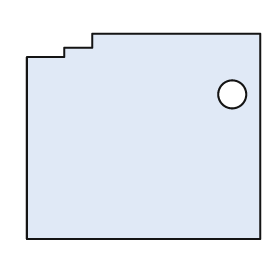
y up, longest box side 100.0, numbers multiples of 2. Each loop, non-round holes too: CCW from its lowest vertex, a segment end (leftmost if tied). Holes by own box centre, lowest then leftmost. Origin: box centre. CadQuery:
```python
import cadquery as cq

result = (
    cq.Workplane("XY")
    .moveTo(-50.0, -44.0)
    .lineTo(50.0, -44.0)
    .lineTo(50.0, 44.0)
    .lineTo(-22.0, 44.0)
    .lineTo(-22.0, 38.0)
    .lineTo(-34.0, 38.0)
    .lineTo(-34.0, 34.0)
    .lineTo(-50.0, 34.0)
    .close()
    .moveTo(38.0, 18.0)
    .circle(6.0)
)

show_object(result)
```